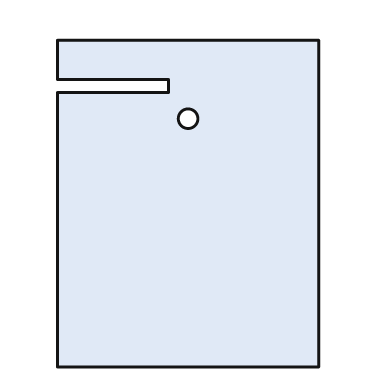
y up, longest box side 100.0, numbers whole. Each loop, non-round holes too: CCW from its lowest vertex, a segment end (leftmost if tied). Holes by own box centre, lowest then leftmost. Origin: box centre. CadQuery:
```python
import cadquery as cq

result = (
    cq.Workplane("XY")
    .moveTo(-40.0, -50.0)
    .lineTo(40.0, -50.0)
    .lineTo(40.0, 50.0)
    .lineTo(-40.0, 50.0)
    .lineTo(-40.0, 38.0)
    .lineTo(-6.0, 38.0)
    .lineTo(-6.0, 34.0)
    .lineTo(-40.0, 34.0)
    .close()
    .moveTo(0.0, 26.0)
    .circle(3.0)
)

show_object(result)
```